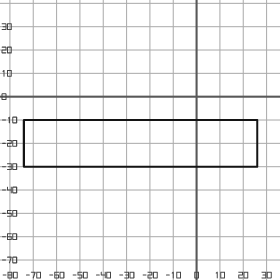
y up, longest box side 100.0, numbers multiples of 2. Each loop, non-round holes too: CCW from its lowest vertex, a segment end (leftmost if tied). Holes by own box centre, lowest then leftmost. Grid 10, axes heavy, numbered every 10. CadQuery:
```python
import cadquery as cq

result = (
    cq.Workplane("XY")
    .moveTo(-74.0, -30.0)
    .lineTo(26.0, -30.0)
    .lineTo(26.0, -10.0)
    .lineTo(-74.0, -10.0)
    .close()
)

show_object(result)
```